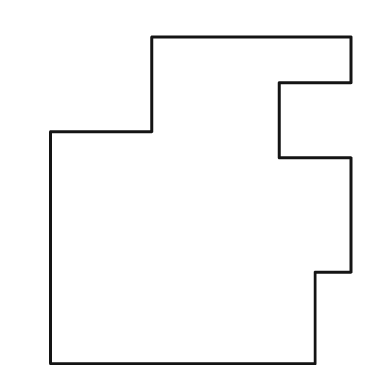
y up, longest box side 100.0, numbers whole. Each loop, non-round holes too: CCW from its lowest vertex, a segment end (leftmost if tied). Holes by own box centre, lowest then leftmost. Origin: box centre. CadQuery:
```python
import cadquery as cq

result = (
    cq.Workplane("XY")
    .moveTo(-46.0, -50.0)
    .lineTo(35.0, -50.0)
    .lineTo(35.0, -22.0)
    .lineTo(46.0, -22.0)
    .lineTo(46.0, 13.0)
    .lineTo(24.0, 13.0)
    .lineTo(24.0, 36.0)
    .lineTo(46.0, 36.0)
    .lineTo(46.0, 50.0)
    .lineTo(-15.0, 50.0)
    .lineTo(-15.0, 21.0)
    .lineTo(-46.0, 21.0)
    .close()
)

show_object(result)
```